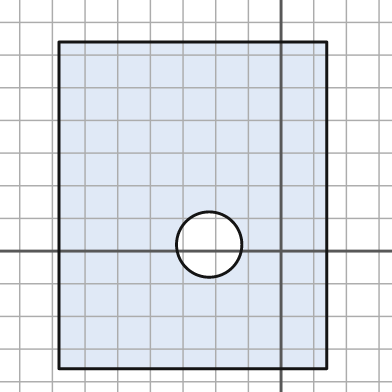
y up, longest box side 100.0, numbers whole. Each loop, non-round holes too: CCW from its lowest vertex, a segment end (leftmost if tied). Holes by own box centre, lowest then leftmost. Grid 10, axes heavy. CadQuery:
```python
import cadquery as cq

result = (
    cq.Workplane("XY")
    .moveTo(-68.0, -36.0)
    .lineTo(14.0, -36.0)
    .lineTo(14.0, 64.0)
    .lineTo(-68.0, 64.0)
    .close()
    .moveTo(-22.0, 2.0)
    .circle(10.0)
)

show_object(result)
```